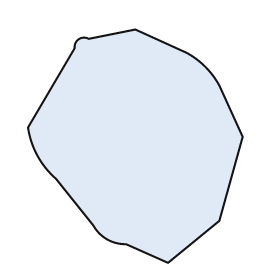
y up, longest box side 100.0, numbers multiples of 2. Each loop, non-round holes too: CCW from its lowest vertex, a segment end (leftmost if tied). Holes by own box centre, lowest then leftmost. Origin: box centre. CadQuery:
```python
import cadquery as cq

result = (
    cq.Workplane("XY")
    .moveTo(14.0, -50.0)
    .lineTo(36.0, -32.0)
    .lineTo(46.0, 4.0)
    .lineTo(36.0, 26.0)
    .threePointArc((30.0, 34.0), (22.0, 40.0))
    .lineTo(0.0, 50.0)
    .lineTo(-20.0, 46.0)
    .threePointArc((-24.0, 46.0), (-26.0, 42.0))
    .lineTo(-46.0, 8.0)
    .threePointArc((-42.0, -4.0), (-34.0, -14.0))
    .lineTo(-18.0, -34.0)
    .threePointArc((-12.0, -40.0), (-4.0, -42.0))
    .close()
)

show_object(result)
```